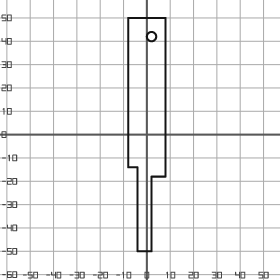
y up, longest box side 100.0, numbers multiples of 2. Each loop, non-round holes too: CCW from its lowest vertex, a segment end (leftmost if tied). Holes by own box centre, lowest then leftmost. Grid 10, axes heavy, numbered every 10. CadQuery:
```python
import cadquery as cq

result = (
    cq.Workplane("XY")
    .moveTo(-4.0, -50.0)
    .lineTo(2.0, -50.0)
    .lineTo(2.0, -18.0)
    .lineTo(8.0, -18.0)
    .lineTo(8.0, 50.0)
    .lineTo(-8.0, 50.0)
    .lineTo(-8.0, -14.0)
    .lineTo(-4.0, -14.0)
    .close()
    .moveTo(2.0, 42.0)
    .circle(2.0)
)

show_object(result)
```